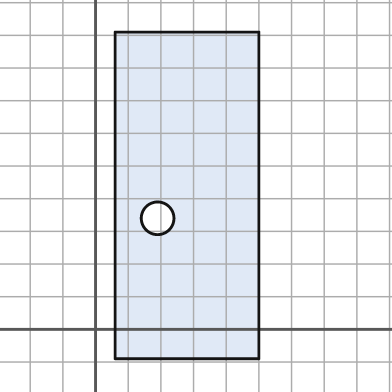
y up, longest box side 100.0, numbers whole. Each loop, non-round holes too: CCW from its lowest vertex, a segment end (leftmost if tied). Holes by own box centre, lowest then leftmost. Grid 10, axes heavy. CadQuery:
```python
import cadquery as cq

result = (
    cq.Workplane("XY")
    .moveTo(6.0, -9.0)
    .lineTo(50.0, -9.0)
    .lineTo(50.0, 91.0)
    .lineTo(6.0, 91.0)
    .close()
    .moveTo(19.0, 34.0)
    .circle(5.0)
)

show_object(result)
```